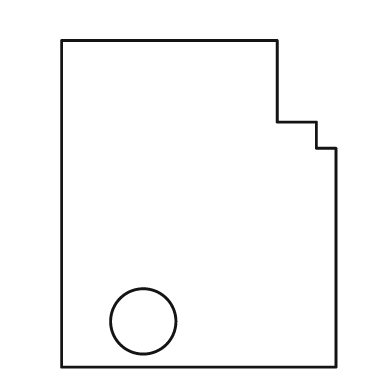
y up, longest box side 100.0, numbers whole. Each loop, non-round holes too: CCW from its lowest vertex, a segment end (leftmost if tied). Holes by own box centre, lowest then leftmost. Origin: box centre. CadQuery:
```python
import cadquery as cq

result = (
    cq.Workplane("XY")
    .moveTo(-42.0, -50.0)
    .lineTo(42.0, -50.0)
    .lineTo(42.0, 17.0)
    .lineTo(36.0, 17.0)
    .lineTo(36.0, 25.0)
    .lineTo(24.0, 25.0)
    .lineTo(24.0, 50.0)
    .lineTo(-42.0, 50.0)
    .close()
    .moveTo(-17.0, -36.0)
    .circle(10.0)
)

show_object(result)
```